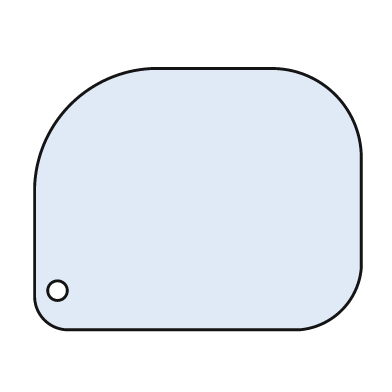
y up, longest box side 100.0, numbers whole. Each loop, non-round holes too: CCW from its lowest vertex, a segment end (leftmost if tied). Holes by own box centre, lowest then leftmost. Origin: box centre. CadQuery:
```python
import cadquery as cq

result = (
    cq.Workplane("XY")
    .moveTo(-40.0, -40.0)
    .lineTo(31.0, -40.0)
    .threePointArc((44.0, -34.0), (50.0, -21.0))
    .lineTo(50.0, 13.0)
    .threePointArc((42.0, 32.0), (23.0, 40.0))
    .lineTo(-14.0, 40.0)
    .threePointArc((-39.0, 29.0), (-50.0, 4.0))
    .lineTo(-50.0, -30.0)
    .threePointArc((-47.0, -37.0), (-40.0, -40.0))
    .close()
    .moveTo(-43.0, -28.0)
    .circle(3.0)
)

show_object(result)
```